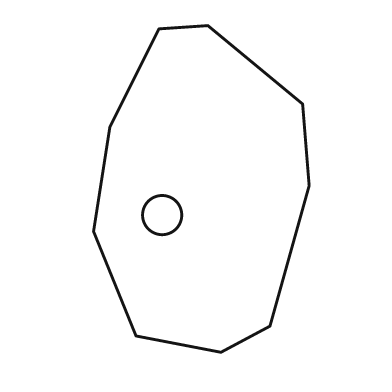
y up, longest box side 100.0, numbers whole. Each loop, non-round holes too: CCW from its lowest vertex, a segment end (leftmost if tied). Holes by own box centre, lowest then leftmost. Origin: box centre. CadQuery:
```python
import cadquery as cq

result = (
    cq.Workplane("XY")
    .moveTo(6.0, -50.0)
    .lineTo(21.0, -42.0)
    .lineTo(33.0, 1.0)
    .lineTo(31.0, 26.0)
    .lineTo(2.0, 50.0)
    .lineTo(-13.0, 49.0)
    .lineTo(-28.0, 19.0)
    .lineTo(-33.0, -13.0)
    .lineTo(-20.0, -45.0)
    .close()
    .moveTo(-12.0, -8.0)
    .circle(6.0)
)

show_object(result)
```